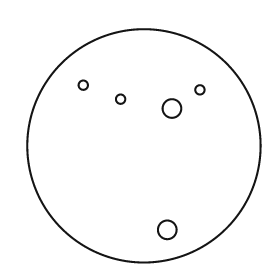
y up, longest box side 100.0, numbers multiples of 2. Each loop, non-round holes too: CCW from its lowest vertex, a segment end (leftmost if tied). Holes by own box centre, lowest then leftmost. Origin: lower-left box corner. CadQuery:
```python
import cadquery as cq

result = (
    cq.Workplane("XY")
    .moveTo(50.0, 50.0)
    .circle(50.0)
    .moveTo(60.0, 14.0)
    .circle(4.0)
    .moveTo(62.0, 66.0)
    .circle(4.0)
    .moveTo(40.0, 70.0)
    .circle(2.0)
    .moveTo(74.0, 74.0)
    .circle(2.0)
    .moveTo(24.0, 76.0)
    .circle(2.0)
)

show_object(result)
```